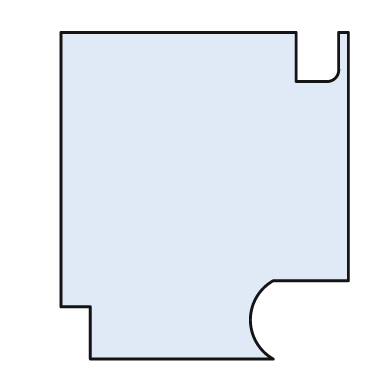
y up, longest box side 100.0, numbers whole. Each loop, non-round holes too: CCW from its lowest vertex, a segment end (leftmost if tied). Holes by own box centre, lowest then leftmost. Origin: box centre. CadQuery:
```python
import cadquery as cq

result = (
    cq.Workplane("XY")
    .moveTo(-35.0, -50.0)
    .lineTo(21.0, -50.0)
    .threePointArc((14.0, -38.0), (21.0, -26.0))
    .lineTo(44.0, -26.0)
    .lineTo(44.0, 50.0)
    .lineTo(41.0, 50.0)
    .lineTo(41.0, 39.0)
    .threePointArc((40.0, 36.0), (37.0, 35.0))
    .lineTo(28.0, 35.0)
    .lineTo(28.0, 50.0)
    .lineTo(-44.0, 50.0)
    .lineTo(-44.0, -34.0)
    .lineTo(-35.0, -34.0)
    .close()
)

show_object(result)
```